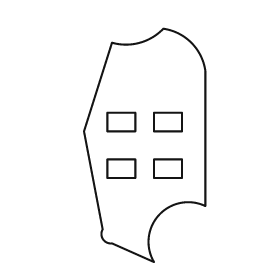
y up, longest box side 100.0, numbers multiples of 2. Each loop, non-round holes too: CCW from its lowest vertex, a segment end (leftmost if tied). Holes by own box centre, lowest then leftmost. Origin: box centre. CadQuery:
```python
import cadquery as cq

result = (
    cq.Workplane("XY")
    .moveTo(4.0, -50.0)
    .threePointArc((6.0, -30.0), (26.0, -26.0))
    .lineTo(26.0, 32.0)
    .threePointArc((20.0, 44.0), (8.0, 50.0))
    .threePointArc((-2.0, 44.0), (-14.0, 44.0))
    .lineTo(-26.0, 6.0)
    .lineTo(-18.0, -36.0)
    .threePointArc((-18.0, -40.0), (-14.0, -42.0))
    .close()
    .moveTo(-16.0, -14.0)
    .lineTo(-4.0, -14.0)
    .lineTo(-4.0, -6.0)
    .lineTo(-16.0, -6.0)
    .close()
    .moveTo(4.0, -14.0)
    .lineTo(16.0, -14.0)
    .lineTo(16.0, -6.0)
    .lineTo(4.0, -6.0)
    .close()
    .moveTo(-16.0, 6.0)
    .lineTo(-4.0, 6.0)
    .lineTo(-4.0, 14.0)
    .lineTo(-16.0, 14.0)
    .close()
    .moveTo(4.0, 6.0)
    .lineTo(16.0, 6.0)
    .lineTo(16.0, 14.0)
    .lineTo(4.0, 14.0)
    .close()
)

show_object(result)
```